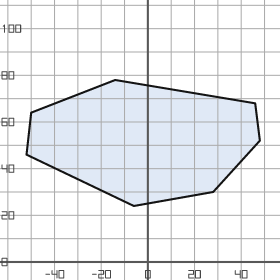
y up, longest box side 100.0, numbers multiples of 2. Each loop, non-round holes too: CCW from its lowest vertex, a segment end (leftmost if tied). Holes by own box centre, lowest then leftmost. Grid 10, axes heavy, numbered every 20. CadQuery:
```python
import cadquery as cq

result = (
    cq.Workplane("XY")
    .moveTo(-6.0, 24.0)
    .lineTo(28.0, 30.0)
    .lineTo(48.0, 52.0)
    .lineTo(46.0, 68.0)
    .lineTo(-14.0, 78.0)
    .lineTo(-50.0, 64.0)
    .lineTo(-52.0, 46.0)
    .close()
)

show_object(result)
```